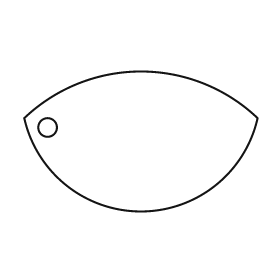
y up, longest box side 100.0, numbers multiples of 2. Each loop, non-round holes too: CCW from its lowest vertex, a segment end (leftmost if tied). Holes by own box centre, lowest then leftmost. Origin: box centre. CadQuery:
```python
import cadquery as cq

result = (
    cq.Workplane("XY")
    .moveTo(-50.0, 10.0)
    .threePointArc((0.0, -30.0), (50.0, 10.0))
    .threePointArc((0.0, 30.0), (-50.0, 10.0))
    .close()
    .moveTo(-40.0, 6.0)
    .circle(4.0)
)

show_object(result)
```